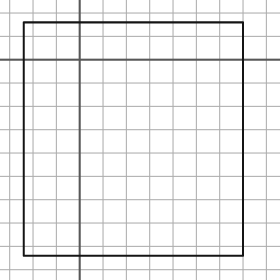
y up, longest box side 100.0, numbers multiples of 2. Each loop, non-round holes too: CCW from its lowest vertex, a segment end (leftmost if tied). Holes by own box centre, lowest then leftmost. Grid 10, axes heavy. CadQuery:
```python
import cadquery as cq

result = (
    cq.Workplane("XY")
    .moveTo(-24.0, -84.0)
    .lineTo(70.0, -84.0)
    .lineTo(70.0, 16.0)
    .lineTo(-24.0, 16.0)
    .close()
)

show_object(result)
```